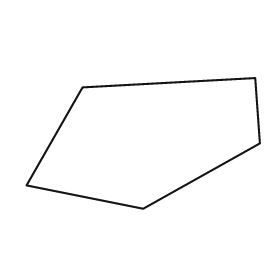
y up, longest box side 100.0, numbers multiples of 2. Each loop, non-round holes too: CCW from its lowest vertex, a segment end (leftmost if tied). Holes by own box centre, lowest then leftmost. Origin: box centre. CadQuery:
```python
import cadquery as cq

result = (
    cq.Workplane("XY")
    .moveTo(0.0, -28.0)
    .lineTo(50.0, 0.0)
    .lineTo(48.0, 28.0)
    .lineTo(-26.0, 24.0)
    .lineTo(-50.0, -18.0)
    .close()
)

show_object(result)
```